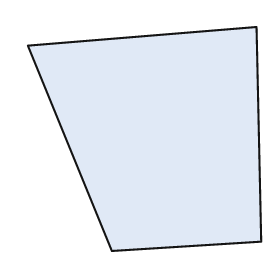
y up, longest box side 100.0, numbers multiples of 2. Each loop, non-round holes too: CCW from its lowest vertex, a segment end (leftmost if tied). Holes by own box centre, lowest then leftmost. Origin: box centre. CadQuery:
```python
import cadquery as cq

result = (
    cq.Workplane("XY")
    .moveTo(-14.0, -48.0)
    .lineTo(50.0, -44.0)
    .lineTo(48.0, 48.0)
    .lineTo(-50.0, 40.0)
    .close()
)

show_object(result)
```